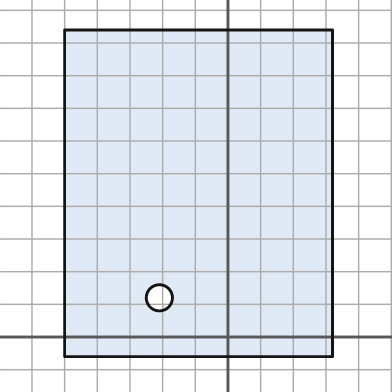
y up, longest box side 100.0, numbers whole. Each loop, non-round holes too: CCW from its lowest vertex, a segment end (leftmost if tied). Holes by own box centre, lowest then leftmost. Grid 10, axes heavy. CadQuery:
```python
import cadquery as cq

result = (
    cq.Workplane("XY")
    .moveTo(-50.0, -6.0)
    .lineTo(32.0, -6.0)
    .lineTo(32.0, 94.0)
    .lineTo(-50.0, 94.0)
    .close()
    .moveTo(-21.0, 12.0)
    .circle(4.0)
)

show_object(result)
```